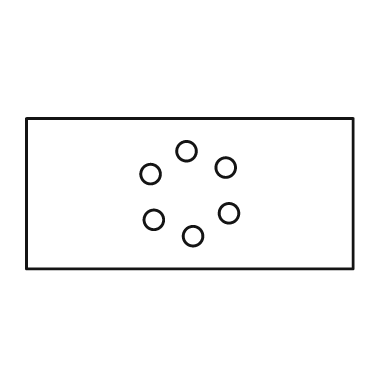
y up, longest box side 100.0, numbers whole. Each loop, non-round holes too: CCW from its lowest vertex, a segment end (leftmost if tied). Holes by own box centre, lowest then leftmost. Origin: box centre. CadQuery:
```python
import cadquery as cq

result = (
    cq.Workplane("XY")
    .moveTo(-50.0, -23.0)
    .lineTo(50.0, -23.0)
    .lineTo(50.0, 23.0)
    .lineTo(-50.0, 23.0)
    .close()
    .moveTo(1.0, -13.0)
    .circle(3.0)
    .moveTo(-11.0, -8.0)
    .circle(3.0)
    .moveTo(12.0, -6.0)
    .circle(3.0)
    .moveTo(-12.0, 6.0)
    .circle(3.0)
    .moveTo(11.0, 8.0)
    .circle(3.0)
    .moveTo(-1.0, 13.0)
    .circle(3.0)
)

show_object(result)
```